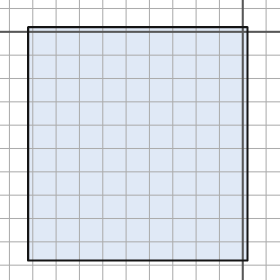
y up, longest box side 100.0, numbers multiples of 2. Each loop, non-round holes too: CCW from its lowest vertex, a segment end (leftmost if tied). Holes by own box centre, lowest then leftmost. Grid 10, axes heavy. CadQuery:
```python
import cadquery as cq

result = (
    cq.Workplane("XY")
    .moveTo(-92.0, -98.0)
    .lineTo(2.0, -98.0)
    .lineTo(2.0, 2.0)
    .lineTo(-92.0, 2.0)
    .close()
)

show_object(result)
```